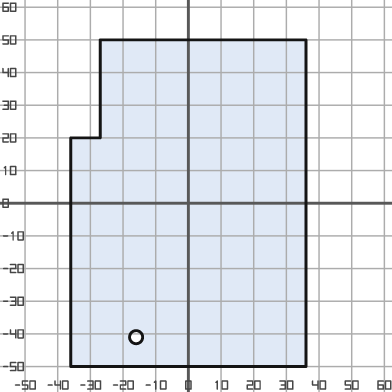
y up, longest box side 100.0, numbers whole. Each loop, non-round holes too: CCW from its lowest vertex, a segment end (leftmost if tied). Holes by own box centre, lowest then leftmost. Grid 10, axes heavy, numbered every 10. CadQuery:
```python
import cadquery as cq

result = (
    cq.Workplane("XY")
    .moveTo(-36.0, -50.0)
    .lineTo(36.0, -50.0)
    .lineTo(36.0, 50.0)
    .lineTo(-27.0, 50.0)
    .lineTo(-27.0, 20.0)
    .lineTo(-36.0, 20.0)
    .close()
    .moveTo(-16.0, -41.0)
    .circle(2.0)
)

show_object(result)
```